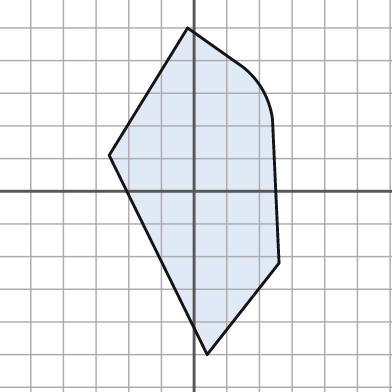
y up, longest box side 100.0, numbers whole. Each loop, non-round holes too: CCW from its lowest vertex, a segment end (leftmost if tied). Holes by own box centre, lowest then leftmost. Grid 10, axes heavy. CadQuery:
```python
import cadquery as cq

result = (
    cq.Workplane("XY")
    .moveTo(4.0, -50.0)
    .lineTo(26.0, -22.0)
    .lineTo(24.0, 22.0)
    .threePointArc((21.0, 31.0), (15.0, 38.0))
    .lineTo(-2.0, 50.0)
    .lineTo(-26.0, 11.0)
    .close()
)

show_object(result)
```